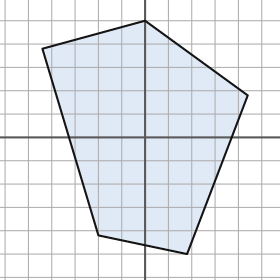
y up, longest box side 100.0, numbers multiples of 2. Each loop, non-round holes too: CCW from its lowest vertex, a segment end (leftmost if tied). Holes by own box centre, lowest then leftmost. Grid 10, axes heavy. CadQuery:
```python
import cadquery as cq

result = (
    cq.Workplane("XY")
    .moveTo(18.0, -50.0)
    .lineTo(44.0, 18.0)
    .lineTo(0.0, 50.0)
    .lineTo(-44.0, 38.0)
    .lineTo(-20.0, -42.0)
    .close()
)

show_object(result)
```